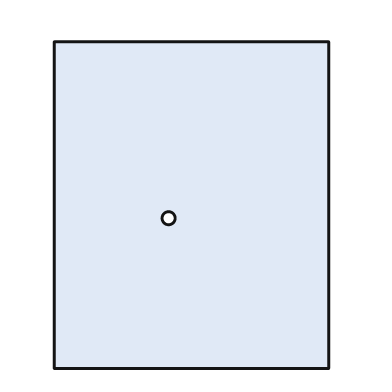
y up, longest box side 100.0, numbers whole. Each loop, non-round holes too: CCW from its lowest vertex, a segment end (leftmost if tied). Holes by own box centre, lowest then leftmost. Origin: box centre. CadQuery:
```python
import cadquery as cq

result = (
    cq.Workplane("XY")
    .moveTo(-42.0, -50.0)
    .lineTo(42.0, -50.0)
    .lineTo(42.0, 50.0)
    .lineTo(-42.0, 50.0)
    .close()
    .moveTo(-7.0, -4.0)
    .circle(2.0)
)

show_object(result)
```